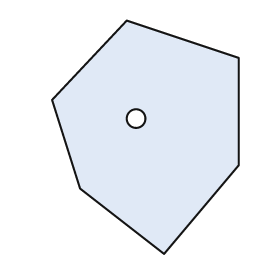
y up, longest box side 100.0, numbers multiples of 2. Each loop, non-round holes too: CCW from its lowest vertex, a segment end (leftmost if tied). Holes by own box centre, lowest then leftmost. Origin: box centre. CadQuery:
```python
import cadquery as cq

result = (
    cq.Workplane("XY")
    .moveTo(8.0, -50.0)
    .lineTo(40.0, -12.0)
    .lineTo(40.0, 34.0)
    .lineTo(-8.0, 50.0)
    .lineTo(-40.0, 16.0)
    .lineTo(-28.0, -22.0)
    .close()
    .moveTo(-4.0, 8.0)
    .circle(4.0)
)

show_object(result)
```